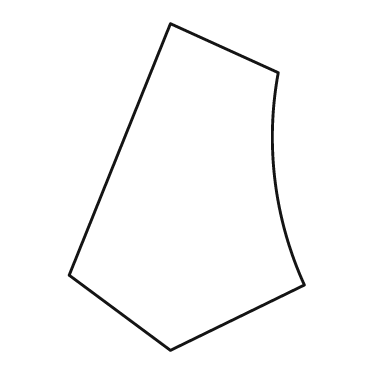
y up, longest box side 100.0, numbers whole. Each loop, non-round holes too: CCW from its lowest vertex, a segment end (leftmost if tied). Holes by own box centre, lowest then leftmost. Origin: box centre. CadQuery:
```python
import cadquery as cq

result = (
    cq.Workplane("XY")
    .moveTo(-5.0, -50.0)
    .lineTo(36.0, -30.0)
    .threePointArc((27.0, 2.0), (28.0, 35.0))
    .lineTo(-5.0, 50.0)
    .lineTo(-36.0, -27.0)
    .close()
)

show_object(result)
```